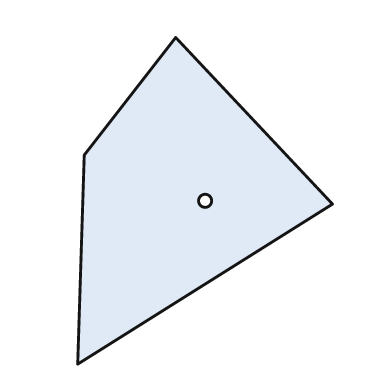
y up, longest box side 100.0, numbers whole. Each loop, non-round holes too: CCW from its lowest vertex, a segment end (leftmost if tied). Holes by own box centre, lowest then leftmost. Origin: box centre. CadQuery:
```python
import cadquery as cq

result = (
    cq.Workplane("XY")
    .moveTo(-39.0, -50.0)
    .lineTo(39.0, -1.0)
    .lineTo(-9.0, 50.0)
    .lineTo(-37.0, 14.0)
    .close()
    .moveTo(0.0, 0.0)
    .circle(2.0)
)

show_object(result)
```